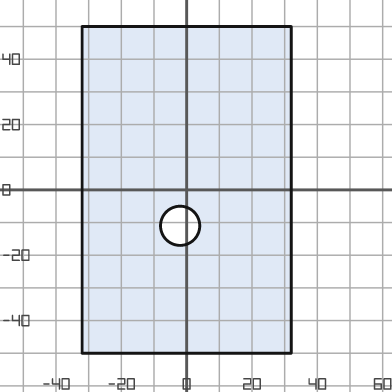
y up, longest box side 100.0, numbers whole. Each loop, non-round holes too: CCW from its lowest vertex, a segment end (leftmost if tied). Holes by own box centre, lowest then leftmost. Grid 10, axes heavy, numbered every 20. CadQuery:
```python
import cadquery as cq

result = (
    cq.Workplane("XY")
    .moveTo(-32.0, -50.0)
    .lineTo(32.0, -50.0)
    .lineTo(32.0, 50.0)
    .lineTo(-32.0, 50.0)
    .close()
    .moveTo(-2.0, -11.0)
    .circle(6.0)
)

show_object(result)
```